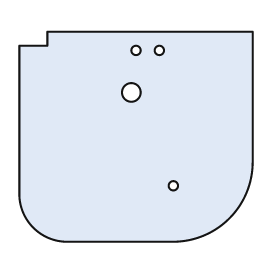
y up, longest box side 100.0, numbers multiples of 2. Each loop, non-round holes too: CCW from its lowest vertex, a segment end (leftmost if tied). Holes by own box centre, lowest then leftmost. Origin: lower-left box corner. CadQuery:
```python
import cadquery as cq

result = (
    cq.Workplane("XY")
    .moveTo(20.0, 0.0)
    .lineTo(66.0, 0.0)
    .threePointArc((90.0, 10.0), (100.0, 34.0))
    .lineTo(100.0, 90.0)
    .lineTo(12.0, 90.0)
    .lineTo(12.0, 84.0)
    .lineTo(0.0, 84.0)
    .lineTo(0.0, 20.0)
    .threePointArc((6.0, 6.0), (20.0, 0.0))
    .close()
    .moveTo(66.0, 24.0)
    .circle(2.0)
    .moveTo(48.0, 64.0)
    .circle(4.0)
    .moveTo(50.0, 82.0)
    .circle(2.0)
    .moveTo(60.0, 82.0)
    .circle(2.0)
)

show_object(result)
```